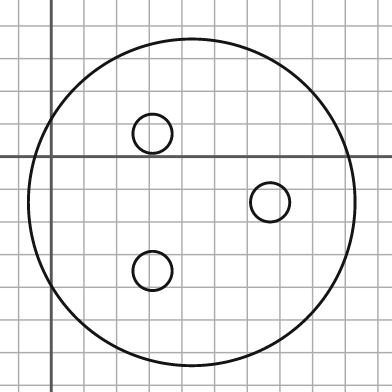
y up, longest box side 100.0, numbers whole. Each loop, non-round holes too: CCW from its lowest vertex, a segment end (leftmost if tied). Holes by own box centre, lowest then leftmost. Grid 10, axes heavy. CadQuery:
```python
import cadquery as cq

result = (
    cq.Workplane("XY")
    .moveTo(43.0, -14.0)
    .circle(50.0)
    .moveTo(31.0, -35.0)
    .circle(6.0)
    .moveTo(67.0, -14.0)
    .circle(6.0)
    .moveTo(31.0, 7.0)
    .circle(6.0)
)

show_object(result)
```